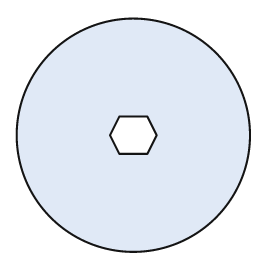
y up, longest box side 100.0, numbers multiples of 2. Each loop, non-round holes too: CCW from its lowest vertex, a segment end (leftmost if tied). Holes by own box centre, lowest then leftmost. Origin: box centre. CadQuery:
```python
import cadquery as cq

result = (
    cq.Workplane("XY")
    .moveTo(0.0, 0.0)
    .circle(50.0)
    .moveTo(-6.0, -8.0)
    .lineTo(6.0, -8.0)
    .lineTo(10.0, 0.0)
    .lineTo(6.0, 8.0)
    .lineTo(-6.0, 8.0)
    .lineTo(-10.0, 0.0)
    .close()
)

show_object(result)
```